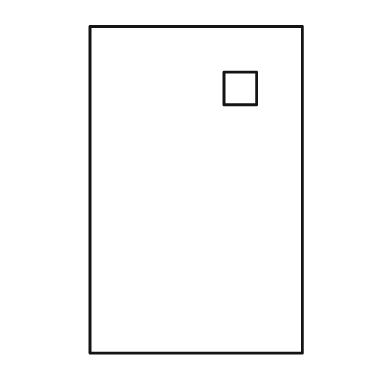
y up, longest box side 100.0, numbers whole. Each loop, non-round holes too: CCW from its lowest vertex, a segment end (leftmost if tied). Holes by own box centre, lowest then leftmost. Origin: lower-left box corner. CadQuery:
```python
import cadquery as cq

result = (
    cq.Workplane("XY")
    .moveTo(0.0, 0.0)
    .lineTo(65.0, 0.0)
    .lineTo(65.0, 100.0)
    .lineTo(0.0, 100.0)
    .close()
    .moveTo(41.0, 76.0)
    .lineTo(51.0, 76.0)
    .lineTo(51.0, 86.0)
    .lineTo(41.0, 86.0)
    .close()
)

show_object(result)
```